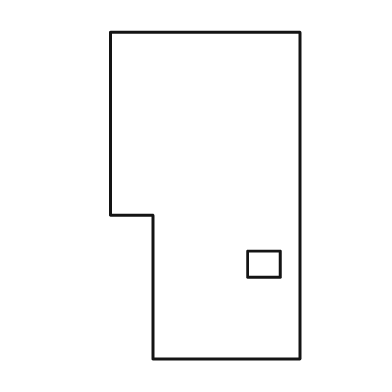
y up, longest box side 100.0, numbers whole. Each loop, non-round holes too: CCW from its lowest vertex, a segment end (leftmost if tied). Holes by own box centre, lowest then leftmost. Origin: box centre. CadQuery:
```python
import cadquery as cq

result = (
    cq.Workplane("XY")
    .moveTo(-16.0, -50.0)
    .lineTo(29.0, -50.0)
    .lineTo(29.0, 50.0)
    .lineTo(-29.0, 50.0)
    .lineTo(-29.0, -6.0)
    .lineTo(-16.0, -6.0)
    .close()
    .moveTo(13.0, -25.0)
    .lineTo(23.0, -25.0)
    .lineTo(23.0, -17.0)
    .lineTo(13.0, -17.0)
    .close()
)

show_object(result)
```